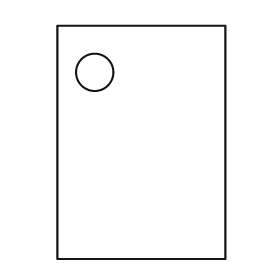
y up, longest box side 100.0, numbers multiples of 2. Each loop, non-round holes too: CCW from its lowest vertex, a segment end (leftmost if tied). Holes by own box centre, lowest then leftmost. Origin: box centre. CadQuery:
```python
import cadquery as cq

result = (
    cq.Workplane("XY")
    .moveTo(-36.0, -50.0)
    .lineTo(36.0, -50.0)
    .lineTo(36.0, 50.0)
    .lineTo(-36.0, 50.0)
    .close()
    .moveTo(-20.0, 30.0)
    .circle(8.0)
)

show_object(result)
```